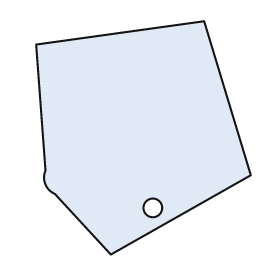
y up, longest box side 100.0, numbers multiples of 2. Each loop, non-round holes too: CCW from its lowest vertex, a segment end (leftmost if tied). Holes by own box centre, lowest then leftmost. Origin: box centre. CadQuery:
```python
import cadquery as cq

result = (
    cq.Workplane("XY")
    .moveTo(-14.0, -50.0)
    .lineTo(46.0, -16.0)
    .lineTo(26.0, 50.0)
    .lineTo(-46.0, 40.0)
    .lineTo(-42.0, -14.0)
    .threePointArc((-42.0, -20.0), (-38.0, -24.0))
    .close()
    .moveTo(4.0, -30.0)
    .circle(4.0)
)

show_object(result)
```